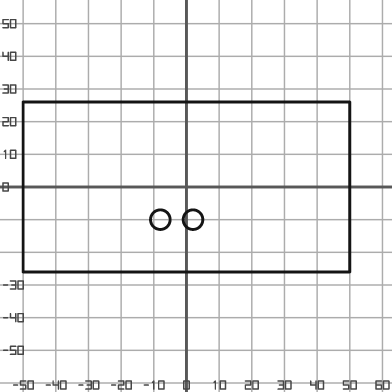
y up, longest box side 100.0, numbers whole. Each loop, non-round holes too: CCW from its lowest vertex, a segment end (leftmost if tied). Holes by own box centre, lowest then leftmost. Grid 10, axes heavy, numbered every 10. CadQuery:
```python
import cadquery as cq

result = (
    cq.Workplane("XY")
    .moveTo(-50.0, -26.0)
    .lineTo(50.0, -26.0)
    .lineTo(50.0, 26.0)
    .lineTo(-50.0, 26.0)
    .close()
    .moveTo(-8.0, -10.0)
    .circle(3.0)
    .moveTo(2.0, -10.0)
    .circle(3.0)
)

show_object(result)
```